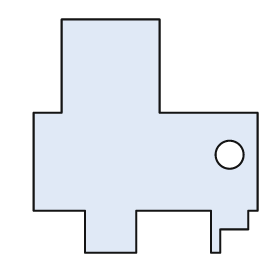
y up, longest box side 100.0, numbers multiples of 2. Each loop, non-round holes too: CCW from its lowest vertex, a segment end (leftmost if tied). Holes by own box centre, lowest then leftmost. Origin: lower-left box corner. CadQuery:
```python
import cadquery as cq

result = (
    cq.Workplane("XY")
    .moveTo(22.0, 0.0)
    .lineTo(44.0, 0.0)
    .lineTo(44.0, 18.0)
    .lineTo(76.0, 18.0)
    .lineTo(76.0, 0.0)
    .lineTo(80.0, 0.0)
    .lineTo(80.0, 10.0)
    .lineTo(92.0, 10.0)
    .lineTo(92.0, 18.0)
    .lineTo(96.0, 18.0)
    .lineTo(96.0, 60.0)
    .lineTo(54.0, 60.0)
    .lineTo(54.0, 100.0)
    .lineTo(12.0, 100.0)
    .lineTo(12.0, 60.0)
    .lineTo(0.0, 60.0)
    .lineTo(0.0, 18.0)
    .lineTo(22.0, 18.0)
    .close()
    .moveTo(84.0, 42.0)
    .circle(6.0)
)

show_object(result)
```